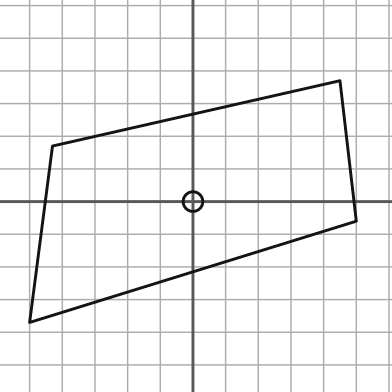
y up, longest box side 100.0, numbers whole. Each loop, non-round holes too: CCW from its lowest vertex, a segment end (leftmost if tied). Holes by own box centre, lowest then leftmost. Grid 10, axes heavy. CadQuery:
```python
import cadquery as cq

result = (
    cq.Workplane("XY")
    .moveTo(-50.0, -37.0)
    .lineTo(50.0, -6.0)
    .lineTo(45.0, 37.0)
    .lineTo(-43.0, 17.0)
    .close()
    .moveTo(0.0, 0.0)
    .circle(3.0)
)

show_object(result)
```